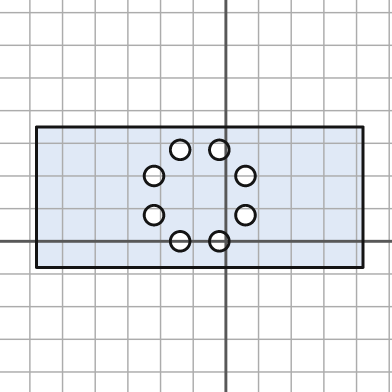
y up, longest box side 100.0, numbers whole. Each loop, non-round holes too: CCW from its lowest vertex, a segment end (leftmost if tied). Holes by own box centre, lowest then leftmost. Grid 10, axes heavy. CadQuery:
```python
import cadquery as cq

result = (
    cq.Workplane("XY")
    .moveTo(-58.0, -8.0)
    .lineTo(42.0, -8.0)
    .lineTo(42.0, 35.0)
    .lineTo(-58.0, 35.0)
    .close()
    .moveTo(-14.0, 0.0)
    .circle(3.0)
    .moveTo(-2.0, 0.0)
    .circle(3.0)
    .moveTo(-22.0, 8.0)
    .circle(3.0)
    .moveTo(6.0, 8.0)
    .circle(3.0)
    .moveTo(-22.0, 20.0)
    .circle(3.0)
    .moveTo(6.0, 20.0)
    .circle(3.0)
    .moveTo(-14.0, 28.0)
    .circle(3.0)
    .moveTo(-2.0, 28.0)
    .circle(3.0)
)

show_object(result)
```